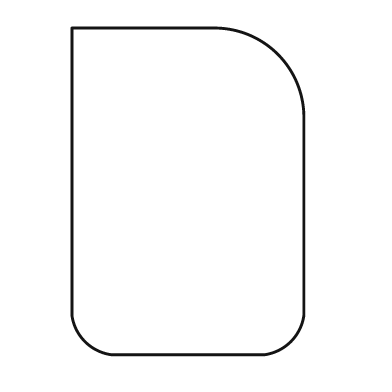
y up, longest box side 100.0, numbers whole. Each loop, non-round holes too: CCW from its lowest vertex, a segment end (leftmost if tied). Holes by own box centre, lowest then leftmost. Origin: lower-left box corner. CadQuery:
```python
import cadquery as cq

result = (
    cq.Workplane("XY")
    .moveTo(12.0, 0.0)
    .lineTo(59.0, 0.0)
    .threePointArc((67.0, 4.0), (71.0, 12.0))
    .lineTo(71.0, 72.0)
    .threePointArc((63.0, 92.0), (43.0, 100.0))
    .lineTo(0.0, 100.0)
    .lineTo(0.0, 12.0)
    .threePointArc((4.0, 4.0), (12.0, 0.0))
    .close()
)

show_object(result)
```